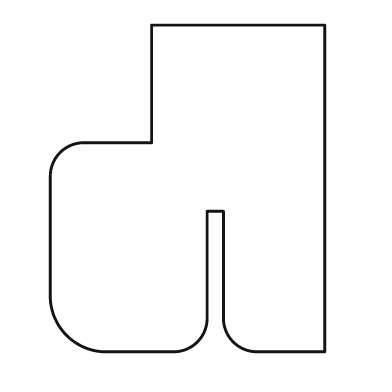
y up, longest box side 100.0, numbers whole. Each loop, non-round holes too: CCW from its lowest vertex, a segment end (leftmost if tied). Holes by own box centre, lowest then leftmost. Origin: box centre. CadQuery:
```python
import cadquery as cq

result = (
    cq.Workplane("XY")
    .moveTo(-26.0, -50.0)
    .lineTo(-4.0, -50.0)
    .threePointArc((3.0, -47.0), (6.0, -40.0))
    .lineTo(6.0, -7.0)
    .lineTo(11.0, -7.0)
    .lineTo(11.0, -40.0)
    .threePointArc((14.0, -47.0), (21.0, -50.0))
    .lineTo(42.0, -50.0)
    .lineTo(42.0, 50.0)
    .lineTo(-11.0, 50.0)
    .lineTo(-11.0, 14.0)
    .lineTo(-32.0, 14.0)
    .threePointArc((-39.0, 11.0), (-42.0, 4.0))
    .lineTo(-42.0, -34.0)
    .threePointArc((-37.0, -45.0), (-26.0, -50.0))
    .close()
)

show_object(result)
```